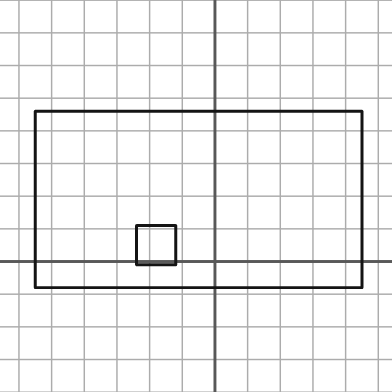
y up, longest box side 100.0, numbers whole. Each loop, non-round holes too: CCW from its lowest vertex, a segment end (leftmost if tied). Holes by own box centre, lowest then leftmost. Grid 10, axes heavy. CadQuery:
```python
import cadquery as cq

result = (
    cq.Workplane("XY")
    .moveTo(-55.0, -8.0)
    .lineTo(45.0, -8.0)
    .lineTo(45.0, 46.0)
    .lineTo(-55.0, 46.0)
    .close()
    .moveTo(-24.0, -1.0)
    .lineTo(-12.0, -1.0)
    .lineTo(-12.0, 11.0)
    .lineTo(-24.0, 11.0)
    .close()
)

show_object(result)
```